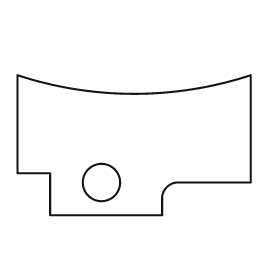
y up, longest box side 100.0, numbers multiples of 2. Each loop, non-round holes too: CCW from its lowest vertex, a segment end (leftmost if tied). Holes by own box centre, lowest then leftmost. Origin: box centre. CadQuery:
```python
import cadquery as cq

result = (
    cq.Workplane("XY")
    .moveTo(-36.0, -30.0)
    .lineTo(12.0, -30.0)
    .lineTo(12.0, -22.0)
    .threePointArc((14.0, -18.0), (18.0, -16.0))
    .lineTo(50.0, -16.0)
    .lineTo(50.0, 30.0)
    .threePointArc((0.0, 22.0), (-50.0, 30.0))
    .lineTo(-50.0, -12.0)
    .lineTo(-36.0, -12.0)
    .close()
    .moveTo(-14.0, -16.0)
    .circle(8.0)
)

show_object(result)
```